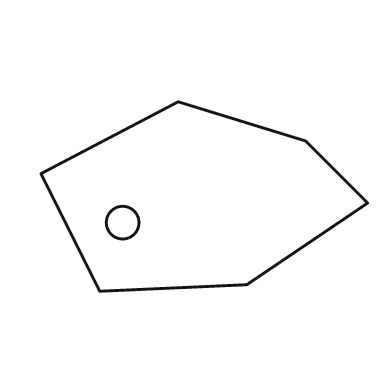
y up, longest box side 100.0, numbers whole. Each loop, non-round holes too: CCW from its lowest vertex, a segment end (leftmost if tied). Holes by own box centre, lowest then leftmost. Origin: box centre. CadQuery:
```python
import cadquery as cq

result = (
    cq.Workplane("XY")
    .moveTo(-32.0, -29.0)
    .lineTo(13.0, -27.0)
    .lineTo(50.0, -2.0)
    .lineTo(31.0, 17.0)
    .lineTo(-8.0, 29.0)
    .lineTo(-50.0, 7.0)
    .close()
    .moveTo(-25.0, -8.0)
    .circle(5.0)
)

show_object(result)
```